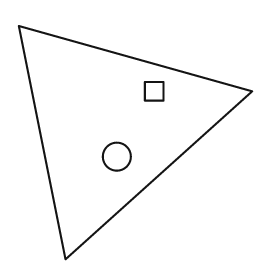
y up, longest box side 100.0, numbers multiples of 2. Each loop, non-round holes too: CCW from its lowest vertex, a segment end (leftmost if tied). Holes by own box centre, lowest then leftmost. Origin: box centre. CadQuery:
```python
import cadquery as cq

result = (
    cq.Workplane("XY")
    .moveTo(-30.0, -50.0)
    .lineTo(50.0, 22.0)
    .lineTo(-50.0, 50.0)
    .close()
    .moveTo(-8.0, -6.0)
    .circle(6.0)
    .moveTo(4.0, 18.0)
    .lineTo(12.0, 18.0)
    .lineTo(12.0, 26.0)
    .lineTo(4.0, 26.0)
    .close()
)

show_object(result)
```